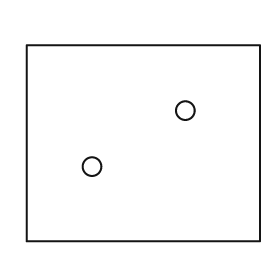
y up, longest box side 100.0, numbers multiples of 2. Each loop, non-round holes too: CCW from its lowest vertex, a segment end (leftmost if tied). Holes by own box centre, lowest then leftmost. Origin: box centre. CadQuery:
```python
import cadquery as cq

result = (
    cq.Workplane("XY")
    .moveTo(-50.0, -42.0)
    .lineTo(50.0, -42.0)
    .lineTo(50.0, 42.0)
    .lineTo(-50.0, 42.0)
    .close()
    .moveTo(-22.0, -10.0)
    .circle(4.0)
    .moveTo(18.0, 14.0)
    .circle(4.0)
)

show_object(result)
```